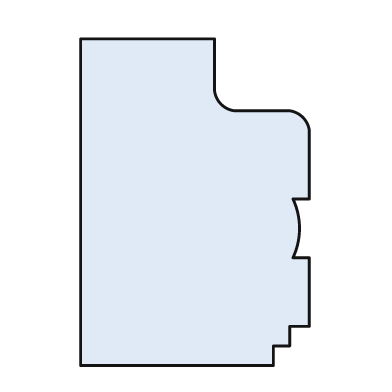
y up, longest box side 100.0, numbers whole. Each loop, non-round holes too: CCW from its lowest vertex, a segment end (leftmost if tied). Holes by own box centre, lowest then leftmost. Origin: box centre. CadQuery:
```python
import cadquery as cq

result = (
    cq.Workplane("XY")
    .moveTo(-35.0, -50.0)
    .lineTo(24.0, -50.0)
    .lineTo(24.0, -44.0)
    .lineTo(29.0, -44.0)
    .lineTo(29.0, -38.0)
    .lineTo(35.0, -38.0)
    .lineTo(35.0, -17.0)
    .lineTo(30.0, -17.0)
    .threePointArc((32.0, -8.0), (30.0, 1.0))
    .lineTo(35.0, 1.0)
    .lineTo(35.0, 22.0)
    .threePointArc((33.0, 26.0), (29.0, 28.0))
    .lineTo(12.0, 28.0)
    .threePointArc((8.0, 30.0), (6.0, 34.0))
    .lineTo(6.0, 50.0)
    .lineTo(-35.0, 50.0)
    .close()
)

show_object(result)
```